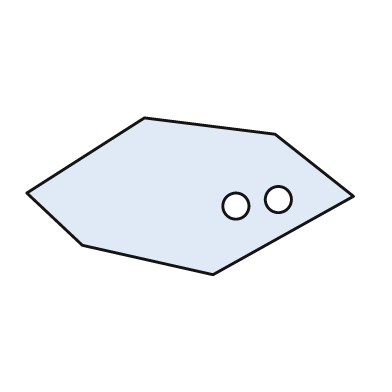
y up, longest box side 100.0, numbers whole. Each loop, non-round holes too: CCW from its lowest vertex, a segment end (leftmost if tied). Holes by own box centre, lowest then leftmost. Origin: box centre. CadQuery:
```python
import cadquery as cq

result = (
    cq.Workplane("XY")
    .moveTo(7.0, -24.0)
    .lineTo(50.0, 0.0)
    .lineTo(26.0, 19.0)
    .lineTo(-14.0, 24.0)
    .lineTo(-50.0, 1.0)
    .lineTo(-33.0, -15.0)
    .close()
    .moveTo(14.0, -3.0)
    .circle(4.0)
    .moveTo(27.0, -1.0)
    .circle(4.0)
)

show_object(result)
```